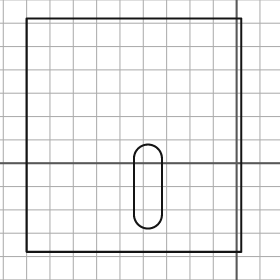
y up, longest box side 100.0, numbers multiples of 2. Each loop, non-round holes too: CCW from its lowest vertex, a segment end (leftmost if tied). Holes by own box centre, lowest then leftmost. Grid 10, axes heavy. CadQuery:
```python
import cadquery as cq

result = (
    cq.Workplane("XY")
    .moveTo(-90.0, -38.0)
    .lineTo(2.0, -38.0)
    .lineTo(2.0, 62.0)
    .lineTo(-90.0, 62.0)
    .close()
    .moveTo(-44.0, -22.0)
    .threePointArc((-38.0, -28.0), (-32.0, -22.0))
    .lineTo(-32.0, 2.0)
    .threePointArc((-38.0, 8.0), (-44.0, 2.0))
    .close()
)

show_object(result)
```